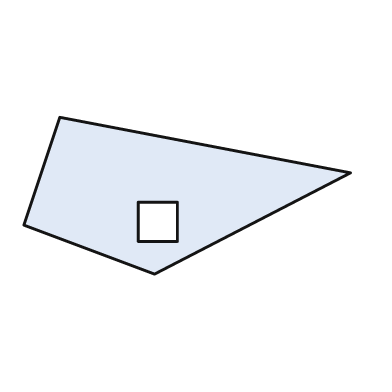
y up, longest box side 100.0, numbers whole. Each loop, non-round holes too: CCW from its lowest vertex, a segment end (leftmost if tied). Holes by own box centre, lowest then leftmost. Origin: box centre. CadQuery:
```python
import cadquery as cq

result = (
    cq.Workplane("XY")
    .moveTo(-10.0, -24.0)
    .lineTo(50.0, 7.0)
    .lineTo(-39.0, 24.0)
    .lineTo(-50.0, -9.0)
    .close()
    .moveTo(-15.0, -14.0)
    .lineTo(-3.0, -14.0)
    .lineTo(-3.0, -2.0)
    .lineTo(-15.0, -2.0)
    .close()
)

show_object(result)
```